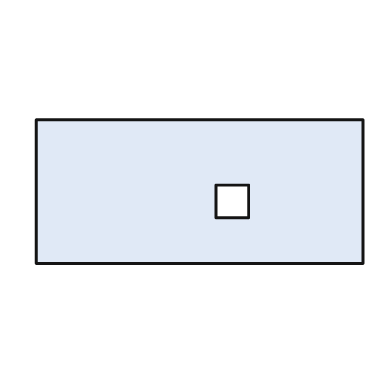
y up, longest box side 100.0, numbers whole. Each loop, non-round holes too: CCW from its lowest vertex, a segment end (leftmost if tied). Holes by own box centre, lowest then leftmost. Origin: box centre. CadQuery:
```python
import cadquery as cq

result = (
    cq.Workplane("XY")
    .moveTo(-50.0, -22.0)
    .lineTo(50.0, -22.0)
    .lineTo(50.0, 22.0)
    .lineTo(-50.0, 22.0)
    .close()
    .moveTo(5.0, -8.0)
    .lineTo(15.0, -8.0)
    .lineTo(15.0, 2.0)
    .lineTo(5.0, 2.0)
    .close()
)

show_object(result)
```